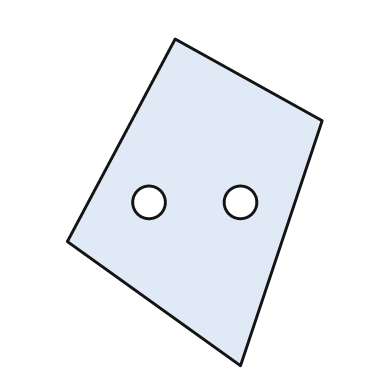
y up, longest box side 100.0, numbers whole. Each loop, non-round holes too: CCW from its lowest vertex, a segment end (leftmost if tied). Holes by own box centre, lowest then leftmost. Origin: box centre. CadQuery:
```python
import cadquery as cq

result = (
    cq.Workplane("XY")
    .moveTo(14.0, -50.0)
    .lineTo(39.0, 25.0)
    .lineTo(-6.0, 50.0)
    .lineTo(-39.0, -12.0)
    .close()
    .moveTo(-14.0, 0.0)
    .circle(5.0)
    .moveTo(14.0, 0.0)
    .circle(5.0)
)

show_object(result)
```